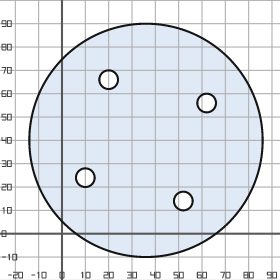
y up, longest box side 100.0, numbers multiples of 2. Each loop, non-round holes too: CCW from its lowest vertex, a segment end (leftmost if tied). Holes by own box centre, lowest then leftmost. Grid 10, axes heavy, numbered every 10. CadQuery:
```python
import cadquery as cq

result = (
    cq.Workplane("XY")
    .moveTo(36.0, 40.0)
    .circle(50.0)
    .moveTo(52.0, 14.0)
    .circle(4.0)
    .moveTo(10.0, 24.0)
    .circle(4.0)
    .moveTo(62.0, 56.0)
    .circle(4.0)
    .moveTo(20.0, 66.0)
    .circle(4.0)
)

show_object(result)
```